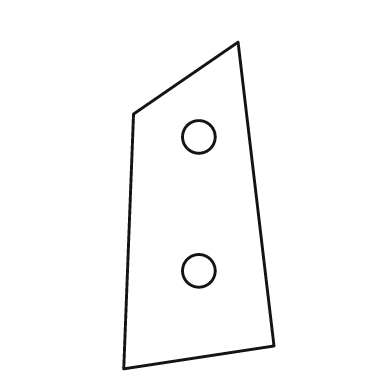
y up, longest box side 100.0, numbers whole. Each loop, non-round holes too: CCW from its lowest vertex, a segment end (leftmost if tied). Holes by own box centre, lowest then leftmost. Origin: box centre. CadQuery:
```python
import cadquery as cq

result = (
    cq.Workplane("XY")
    .moveTo(-23.0, -50.0)
    .lineTo(23.0, -43.0)
    .lineTo(12.0, 50.0)
    .lineTo(-20.0, 28.0)
    .close()
    .moveTo(0.0, -20.0)
    .circle(5.0)
    .moveTo(0.0, 21.0)
    .circle(5.0)
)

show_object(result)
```